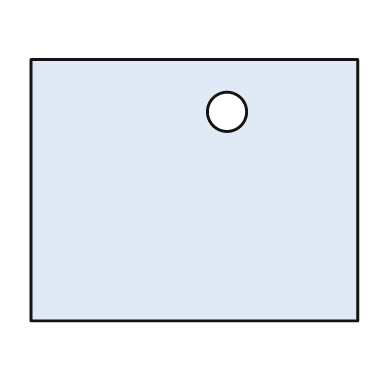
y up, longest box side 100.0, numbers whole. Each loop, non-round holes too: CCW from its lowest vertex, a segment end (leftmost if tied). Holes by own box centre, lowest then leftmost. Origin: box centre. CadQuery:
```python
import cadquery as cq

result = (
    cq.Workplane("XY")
    .moveTo(-50.0, -40.0)
    .lineTo(50.0, -40.0)
    .lineTo(50.0, 40.0)
    .lineTo(-50.0, 40.0)
    .close()
    .moveTo(10.0, 24.0)
    .circle(6.0)
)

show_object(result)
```